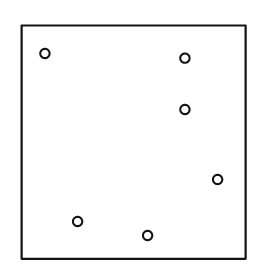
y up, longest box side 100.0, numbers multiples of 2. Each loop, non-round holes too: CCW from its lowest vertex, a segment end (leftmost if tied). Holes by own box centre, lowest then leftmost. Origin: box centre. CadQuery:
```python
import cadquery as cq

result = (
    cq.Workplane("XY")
    .moveTo(-48.0, -50.0)
    .lineTo(48.0, -50.0)
    .lineTo(48.0, 50.0)
    .lineTo(-48.0, 50.0)
    .close()
    .moveTo(6.0, -40.0)
    .circle(2.0)
    .moveTo(-24.0, -34.0)
    .circle(2.0)
    .moveTo(36.0, -16.0)
    .circle(2.0)
    .moveTo(22.0, 14.0)
    .circle(2.0)
    .moveTo(22.0, 36.0)
    .circle(2.0)
    .moveTo(-38.0, 38.0)
    .circle(2.0)
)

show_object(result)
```